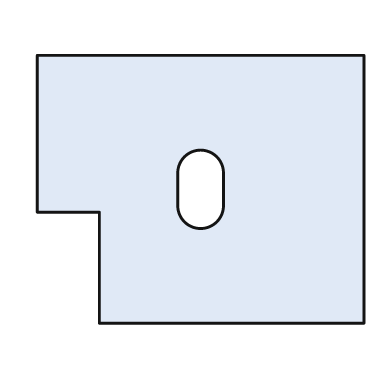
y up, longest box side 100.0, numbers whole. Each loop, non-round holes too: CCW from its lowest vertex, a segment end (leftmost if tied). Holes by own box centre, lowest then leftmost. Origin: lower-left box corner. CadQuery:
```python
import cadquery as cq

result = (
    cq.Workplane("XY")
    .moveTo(19.0, 0.0)
    .lineTo(100.0, 0.0)
    .lineTo(100.0, 82.0)
    .lineTo(0.0, 82.0)
    .lineTo(0.0, 34.0)
    .lineTo(19.0, 34.0)
    .close()
    .moveTo(43.0, 36.0)
    .threePointArc((50.0, 29.0), (57.0, 36.0))
    .lineTo(57.0, 46.0)
    .threePointArc((50.0, 53.0), (43.0, 46.0))
    .close()
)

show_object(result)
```